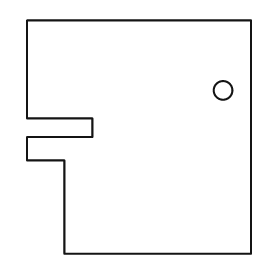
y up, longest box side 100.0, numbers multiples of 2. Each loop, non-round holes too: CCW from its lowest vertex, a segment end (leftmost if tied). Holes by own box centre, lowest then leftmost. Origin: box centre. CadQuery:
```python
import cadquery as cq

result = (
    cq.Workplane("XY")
    .moveTo(-32.0, -50.0)
    .lineTo(48.0, -50.0)
    .lineTo(48.0, 50.0)
    .lineTo(-48.0, 50.0)
    .lineTo(-48.0, 8.0)
    .lineTo(-20.0, 8.0)
    .lineTo(-20.0, 0.0)
    .lineTo(-48.0, 0.0)
    .lineTo(-48.0, -10.0)
    .lineTo(-32.0, -10.0)
    .close()
    .moveTo(36.0, 20.0)
    .circle(4.0)
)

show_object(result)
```